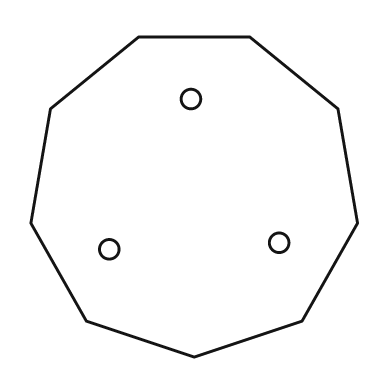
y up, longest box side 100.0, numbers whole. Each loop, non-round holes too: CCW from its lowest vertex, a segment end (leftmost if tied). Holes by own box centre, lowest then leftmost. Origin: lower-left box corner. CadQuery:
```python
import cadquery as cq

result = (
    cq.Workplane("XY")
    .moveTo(50.0, 0.0)
    .lineTo(83.0, 11.0)
    .lineTo(100.0, 41.0)
    .lineTo(94.0, 76.0)
    .lineTo(67.0, 98.0)
    .lineTo(33.0, 98.0)
    .lineTo(6.0, 76.0)
    .lineTo(0.0, 41.0)
    .lineTo(17.0, 11.0)
    .close()
    .moveTo(24.0, 33.0)
    .circle(3.0)
    .moveTo(76.0, 35.0)
    .circle(3.0)
    .moveTo(49.0, 79.0)
    .circle(3.0)
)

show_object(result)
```